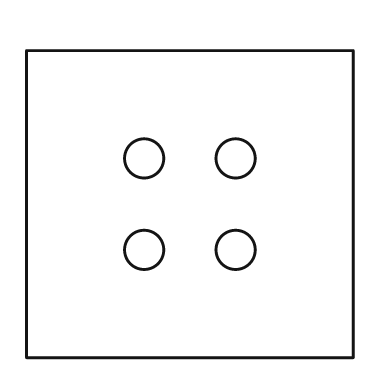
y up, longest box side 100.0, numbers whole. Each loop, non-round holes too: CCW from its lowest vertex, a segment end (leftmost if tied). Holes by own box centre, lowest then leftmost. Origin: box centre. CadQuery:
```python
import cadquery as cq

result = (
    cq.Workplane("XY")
    .moveTo(-50.0, -47.0)
    .lineTo(50.0, -47.0)
    .lineTo(50.0, 47.0)
    .lineTo(-50.0, 47.0)
    .close()
    .moveTo(-14.0, -14.0)
    .circle(6.0)
    .moveTo(14.0, -14.0)
    .circle(6.0)
    .moveTo(-14.0, 14.0)
    .circle(6.0)
    .moveTo(14.0, 14.0)
    .circle(6.0)
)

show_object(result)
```